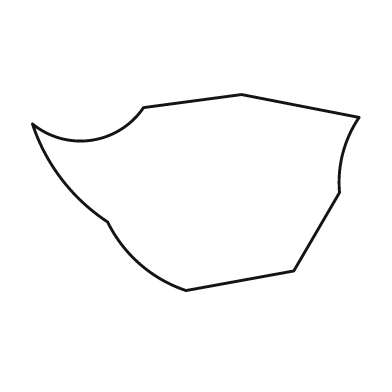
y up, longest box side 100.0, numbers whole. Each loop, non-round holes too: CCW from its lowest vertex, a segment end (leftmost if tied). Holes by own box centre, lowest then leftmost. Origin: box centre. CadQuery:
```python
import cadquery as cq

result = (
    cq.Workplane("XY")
    .moveTo(-3.0, -30.0)
    .lineTo(30.0, -24.0)
    .lineTo(44.0, 0.0)
    .threePointArc((45.0, 12.0), (50.0, 23.0))
    .lineTo(14.0, 30.0)
    .lineTo(-16.0, 26.0)
    .threePointArc((-32.0, 16.0), (-50.0, 21.0))
    .threePointArc((-41.0, 4.0), (-27.0, -9.0))
    .threePointArc((-17.0, -22.0), (-3.0, -30.0))
    .close()
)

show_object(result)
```